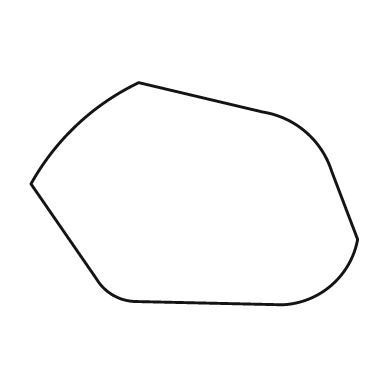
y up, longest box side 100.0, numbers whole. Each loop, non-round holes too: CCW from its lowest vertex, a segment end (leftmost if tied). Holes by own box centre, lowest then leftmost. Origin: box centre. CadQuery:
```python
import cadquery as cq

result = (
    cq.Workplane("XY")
    .moveTo(27.0, -34.0)
    .threePointArc((42.0, -28.0), (50.0, -14.0))
    .lineTo(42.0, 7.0)
    .threePointArc((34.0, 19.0), (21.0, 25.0))
    .lineTo(-17.0, 34.0)
    .threePointArc((-36.0, 21.0), (-50.0, 3.0))
    .lineTo(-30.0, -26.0)
    .threePointArc((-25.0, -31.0), (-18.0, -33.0))
    .close()
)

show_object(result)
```